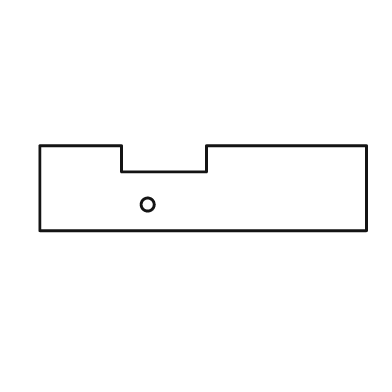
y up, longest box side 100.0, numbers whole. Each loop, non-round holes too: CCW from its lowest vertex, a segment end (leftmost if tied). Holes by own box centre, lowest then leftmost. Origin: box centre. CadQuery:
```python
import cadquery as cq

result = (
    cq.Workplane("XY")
    .moveTo(-50.0, -13.0)
    .lineTo(50.0, -13.0)
    .lineTo(50.0, 13.0)
    .lineTo(1.0, 13.0)
    .lineTo(1.0, 5.0)
    .lineTo(-25.0, 5.0)
    .lineTo(-25.0, 13.0)
    .lineTo(-50.0, 13.0)
    .close()
    .moveTo(-17.0, -5.0)
    .circle(2.0)
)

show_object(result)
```